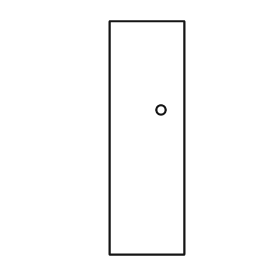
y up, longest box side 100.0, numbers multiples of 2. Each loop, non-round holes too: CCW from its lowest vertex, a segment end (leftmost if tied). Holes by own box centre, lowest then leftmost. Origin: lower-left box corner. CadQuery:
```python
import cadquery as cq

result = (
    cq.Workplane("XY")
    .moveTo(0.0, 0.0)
    .lineTo(32.0, 0.0)
    .lineTo(32.0, 100.0)
    .lineTo(0.0, 100.0)
    .close()
    .moveTo(22.0, 62.0)
    .circle(2.0)
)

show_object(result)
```